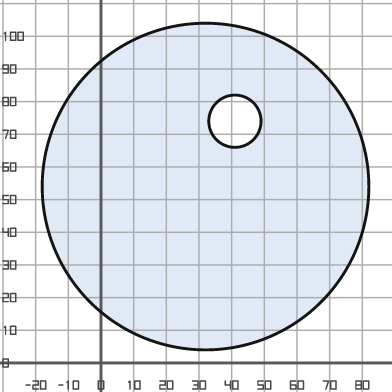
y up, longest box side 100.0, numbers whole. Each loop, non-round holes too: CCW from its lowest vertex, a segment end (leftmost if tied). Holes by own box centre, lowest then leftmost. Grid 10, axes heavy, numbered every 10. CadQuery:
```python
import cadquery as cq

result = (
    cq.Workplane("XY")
    .moveTo(32.0, 54.0)
    .circle(50.0)
    .moveTo(41.0, 74.0)
    .circle(8.0)
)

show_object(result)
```